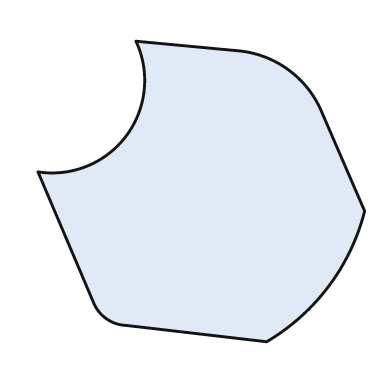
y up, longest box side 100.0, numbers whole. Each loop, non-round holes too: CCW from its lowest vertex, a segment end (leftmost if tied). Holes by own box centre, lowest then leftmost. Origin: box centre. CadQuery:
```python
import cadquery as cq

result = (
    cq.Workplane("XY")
    .moveTo(20.0, -46.0)
    .threePointArc((39.0, -29.0), (50.0, -6.0))
    .lineTo(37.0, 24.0)
    .threePointArc((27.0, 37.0), (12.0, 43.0))
    .lineTo(-20.0, 46.0)
    .threePointArc((-23.0, 17.0), (-50.0, 6.0))
    .lineTo(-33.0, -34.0)
    .threePointArc((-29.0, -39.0), (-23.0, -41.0))
    .close()
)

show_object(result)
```